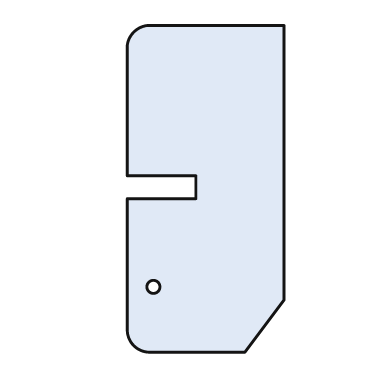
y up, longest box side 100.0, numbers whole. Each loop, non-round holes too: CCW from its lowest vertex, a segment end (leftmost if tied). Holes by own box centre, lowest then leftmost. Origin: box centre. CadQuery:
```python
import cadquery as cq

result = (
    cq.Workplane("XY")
    .moveTo(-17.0, -50.0)
    .lineTo(12.0, -50.0)
    .lineTo(24.0, -34.0)
    .lineTo(24.0, 50.0)
    .lineTo(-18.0, 50.0)
    .threePointArc((-22.0, 48.0), (-24.0, 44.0))
    .lineTo(-24.0, 4.0)
    .lineTo(-3.0, 4.0)
    .lineTo(-3.0, -3.0)
    .lineTo(-24.0, -3.0)
    .lineTo(-24.0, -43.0)
    .threePointArc((-22.0, -48.0), (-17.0, -50.0))
    .close()
    .moveTo(-16.0, -30.0)
    .circle(2.0)
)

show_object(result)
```